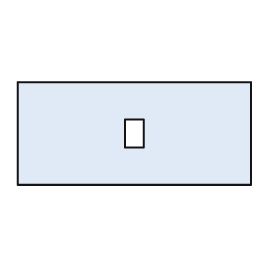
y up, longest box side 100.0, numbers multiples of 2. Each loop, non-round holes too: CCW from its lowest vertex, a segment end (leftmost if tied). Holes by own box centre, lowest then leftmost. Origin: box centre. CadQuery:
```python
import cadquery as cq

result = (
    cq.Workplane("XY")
    .moveTo(-50.0, -22.0)
    .lineTo(50.0, -22.0)
    .lineTo(50.0, 22.0)
    .lineTo(-50.0, 22.0)
    .close()
    .moveTo(-4.0, -6.0)
    .lineTo(4.0, -6.0)
    .lineTo(4.0, 6.0)
    .lineTo(-4.0, 6.0)
    .close()
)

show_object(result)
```